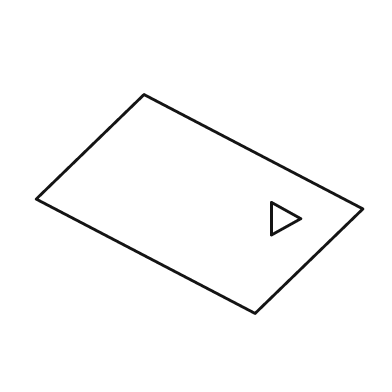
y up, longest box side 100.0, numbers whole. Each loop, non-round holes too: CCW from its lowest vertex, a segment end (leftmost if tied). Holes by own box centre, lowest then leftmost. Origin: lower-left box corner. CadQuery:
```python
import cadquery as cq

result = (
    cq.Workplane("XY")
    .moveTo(67.0, 0.0)
    .lineTo(100.0, 32.0)
    .lineTo(33.0, 67.0)
    .lineTo(0.0, 35.0)
    .close()
    .moveTo(72.0, 24.0)
    .lineTo(81.0, 29.0)
    .lineTo(72.0, 34.0)
    .close()
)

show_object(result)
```